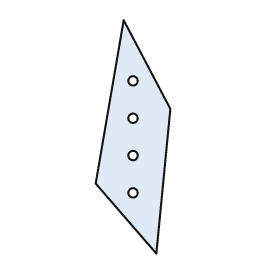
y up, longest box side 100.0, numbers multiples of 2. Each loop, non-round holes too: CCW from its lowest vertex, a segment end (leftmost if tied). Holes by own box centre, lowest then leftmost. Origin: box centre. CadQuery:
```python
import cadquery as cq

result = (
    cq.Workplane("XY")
    .moveTo(10.0, -50.0)
    .lineTo(16.0, 12.0)
    .lineTo(-4.0, 50.0)
    .lineTo(-16.0, -20.0)
    .close()
    .moveTo(0.0, -24.0)
    .circle(2.0)
    .moveTo(0.0, -8.0)
    .circle(2.0)
    .moveTo(0.0, 8.0)
    .circle(2.0)
    .moveTo(0.0, 24.0)
    .circle(2.0)
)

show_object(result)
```